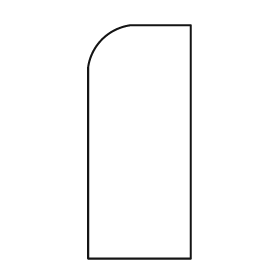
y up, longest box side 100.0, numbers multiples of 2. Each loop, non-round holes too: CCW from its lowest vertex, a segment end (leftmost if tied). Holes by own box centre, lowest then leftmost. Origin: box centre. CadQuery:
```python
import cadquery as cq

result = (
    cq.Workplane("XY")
    .moveTo(-22.0, -50.0)
    .lineTo(22.0, -50.0)
    .lineTo(22.0, 50.0)
    .lineTo(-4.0, 50.0)
    .threePointArc((-16.0, 44.0), (-22.0, 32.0))
    .close()
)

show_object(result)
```